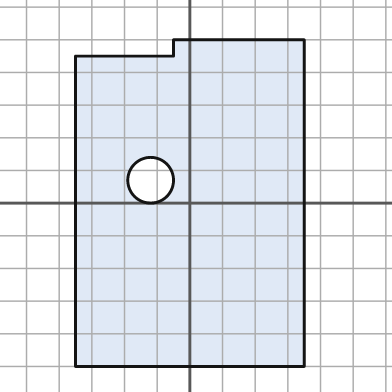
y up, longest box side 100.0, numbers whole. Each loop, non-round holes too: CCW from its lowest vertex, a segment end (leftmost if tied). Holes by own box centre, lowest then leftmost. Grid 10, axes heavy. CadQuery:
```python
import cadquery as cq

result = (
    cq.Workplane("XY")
    .moveTo(-35.0, -50.0)
    .lineTo(35.0, -50.0)
    .lineTo(35.0, 50.0)
    .lineTo(-5.0, 50.0)
    .lineTo(-5.0, 45.0)
    .lineTo(-35.0, 45.0)
    .close()
    .moveTo(-12.0, 7.0)
    .circle(7.0)
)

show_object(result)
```